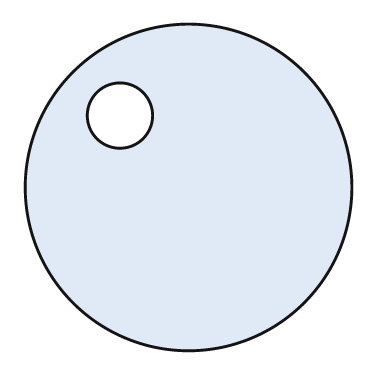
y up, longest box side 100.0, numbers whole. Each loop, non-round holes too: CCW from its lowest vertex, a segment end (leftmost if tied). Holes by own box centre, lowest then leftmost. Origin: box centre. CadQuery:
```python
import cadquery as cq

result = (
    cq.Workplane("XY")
    .moveTo(0.0, 0.0)
    .circle(50.0)
    .moveTo(-21.0, 22.0)
    .circle(10.0)
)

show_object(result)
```